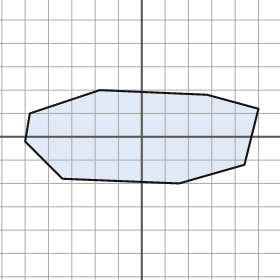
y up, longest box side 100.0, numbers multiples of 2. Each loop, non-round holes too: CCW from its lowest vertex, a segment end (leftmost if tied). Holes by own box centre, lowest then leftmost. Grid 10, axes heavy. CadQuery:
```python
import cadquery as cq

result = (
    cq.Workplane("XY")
    .moveTo(16.0, -20.0)
    .lineTo(44.0, -12.0)
    .lineTo(50.0, 12.0)
    .lineTo(28.0, 18.0)
    .lineTo(-18.0, 20.0)
    .lineTo(-48.0, 10.0)
    .lineTo(-50.0, -2.0)
    .lineTo(-34.0, -18.0)
    .close()
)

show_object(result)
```